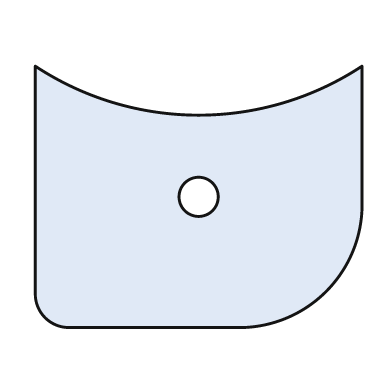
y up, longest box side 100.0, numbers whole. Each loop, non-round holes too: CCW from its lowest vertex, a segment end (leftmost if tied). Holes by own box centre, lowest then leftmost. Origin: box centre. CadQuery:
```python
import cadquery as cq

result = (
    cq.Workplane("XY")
    .moveTo(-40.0, -40.0)
    .lineTo(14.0, -40.0)
    .threePointArc((39.0, -29.0), (50.0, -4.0))
    .lineTo(50.0, 40.0)
    .threePointArc((0.0, 25.0), (-50.0, 40.0))
    .lineTo(-50.0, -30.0)
    .threePointArc((-47.0, -37.0), (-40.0, -40.0))
    .close()
    .moveTo(0.0, 0.0)
    .circle(6.0)
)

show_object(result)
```